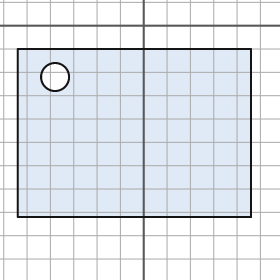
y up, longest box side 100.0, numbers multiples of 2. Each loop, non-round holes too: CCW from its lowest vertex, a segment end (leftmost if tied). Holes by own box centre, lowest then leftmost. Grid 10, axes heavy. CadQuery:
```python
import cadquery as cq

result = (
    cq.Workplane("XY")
    .moveTo(-54.0, -82.0)
    .lineTo(46.0, -82.0)
    .lineTo(46.0, -10.0)
    .lineTo(-54.0, -10.0)
    .close()
    .moveTo(-38.0, -22.0)
    .circle(6.0)
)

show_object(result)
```